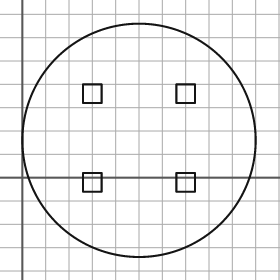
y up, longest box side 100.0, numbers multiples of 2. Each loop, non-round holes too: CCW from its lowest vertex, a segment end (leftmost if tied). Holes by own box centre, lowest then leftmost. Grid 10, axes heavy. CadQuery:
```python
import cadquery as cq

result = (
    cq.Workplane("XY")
    .moveTo(50.0, 16.0)
    .circle(50.0)
    .moveTo(26.0, -6.0)
    .lineTo(34.0, -6.0)
    .lineTo(34.0, 2.0)
    .lineTo(26.0, 2.0)
    .close()
    .moveTo(66.0, -6.0)
    .lineTo(74.0, -6.0)
    .lineTo(74.0, 2.0)
    .lineTo(66.0, 2.0)
    .close()
    .moveTo(26.0, 32.0)
    .lineTo(34.0, 32.0)
    .lineTo(34.0, 40.0)
    .lineTo(26.0, 40.0)
    .close()
    .moveTo(66.0, 32.0)
    .lineTo(74.0, 32.0)
    .lineTo(74.0, 40.0)
    .lineTo(66.0, 40.0)
    .close()
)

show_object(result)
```